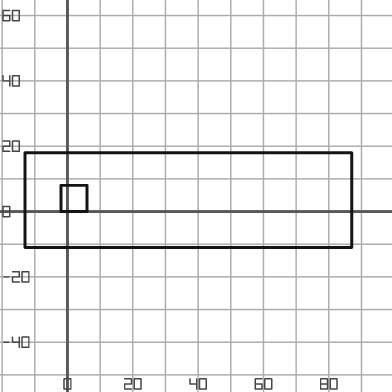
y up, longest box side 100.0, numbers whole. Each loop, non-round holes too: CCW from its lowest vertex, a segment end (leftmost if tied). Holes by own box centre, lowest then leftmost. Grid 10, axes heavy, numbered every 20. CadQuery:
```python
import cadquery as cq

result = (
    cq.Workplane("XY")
    .moveTo(-13.0, -11.0)
    .lineTo(87.0, -11.0)
    .lineTo(87.0, 18.0)
    .lineTo(-13.0, 18.0)
    .close()
    .moveTo(-2.0, 0.0)
    .lineTo(6.0, 0.0)
    .lineTo(6.0, 8.0)
    .lineTo(-2.0, 8.0)
    .close()
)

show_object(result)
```